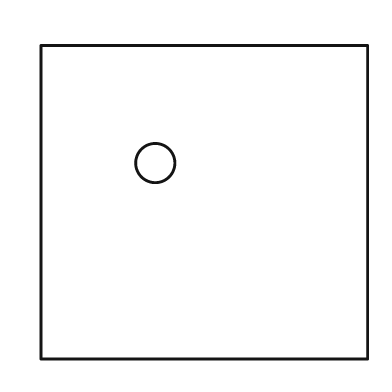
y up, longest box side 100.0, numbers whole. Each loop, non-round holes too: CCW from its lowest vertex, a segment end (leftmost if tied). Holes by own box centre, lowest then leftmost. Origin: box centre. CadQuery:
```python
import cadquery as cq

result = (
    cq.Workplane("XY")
    .moveTo(-50.0, -48.0)
    .lineTo(50.0, -48.0)
    .lineTo(50.0, 48.0)
    .lineTo(-50.0, 48.0)
    .close()
    .moveTo(-15.0, 12.0)
    .circle(6.0)
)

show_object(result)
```